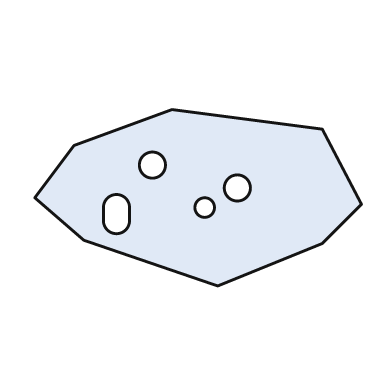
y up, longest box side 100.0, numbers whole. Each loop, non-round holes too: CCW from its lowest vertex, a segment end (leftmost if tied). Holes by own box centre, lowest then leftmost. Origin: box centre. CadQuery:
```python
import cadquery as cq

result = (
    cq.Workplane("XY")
    .moveTo(6.0, -27.0)
    .lineTo(38.0, -14.0)
    .lineTo(50.0, -2.0)
    .lineTo(38.0, 21.0)
    .lineTo(-8.0, 27.0)
    .lineTo(-38.0, 16.0)
    .lineTo(-50.0, 0.0)
    .lineTo(-35.0, -13.0)
    .close()
    .moveTo(-29.0, -7.0)
    .threePointArc((-25.0, -11.0), (-21.0, -7.0))
    .lineTo(-21.0, -3.0)
    .threePointArc((-25.0, 1.0), (-29.0, -3.0))
    .close()
    .moveTo(2.0, -3.0)
    .circle(3.0)
    .moveTo(12.0, 3.0)
    .circle(4.0)
    .moveTo(-14.0, 10.0)
    .circle(4.0)
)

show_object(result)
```